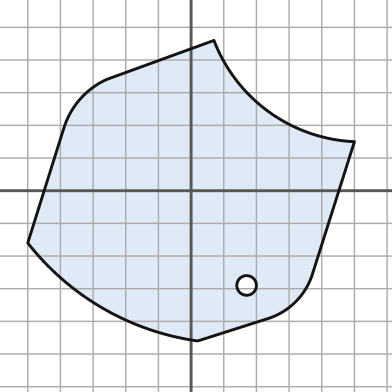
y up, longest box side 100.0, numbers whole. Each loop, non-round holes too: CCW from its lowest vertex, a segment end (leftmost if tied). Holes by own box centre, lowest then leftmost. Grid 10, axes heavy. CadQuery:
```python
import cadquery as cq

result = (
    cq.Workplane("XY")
    .moveTo(2.0, -46.0)
    .lineTo(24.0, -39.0)
    .threePointArc((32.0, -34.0), (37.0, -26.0))
    .lineTo(50.0, 15.0)
    .threePointArc((24.0, 24.0), (7.0, 46.0))
    .lineTo(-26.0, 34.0)
    .threePointArc((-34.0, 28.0), (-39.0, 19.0))
    .lineTo(-50.0, -16.0)
    .threePointArc((-27.0, -36.0), (2.0, -46.0))
    .close()
    .moveTo(17.0, -29.0)
    .circle(3.0)
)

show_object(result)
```